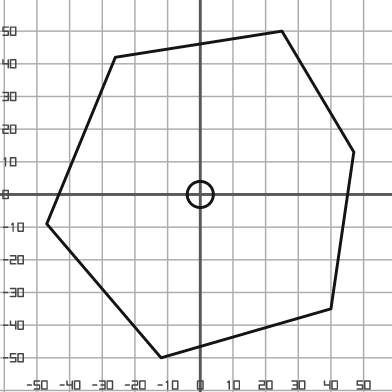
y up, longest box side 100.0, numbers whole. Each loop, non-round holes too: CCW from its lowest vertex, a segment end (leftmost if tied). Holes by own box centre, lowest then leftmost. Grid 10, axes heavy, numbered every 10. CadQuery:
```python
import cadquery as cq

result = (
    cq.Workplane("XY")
    .moveTo(-12.0, -50.0)
    .lineTo(40.0, -35.0)
    .lineTo(47.0, 13.0)
    .lineTo(25.0, 50.0)
    .lineTo(-26.0, 42.0)
    .lineTo(-47.0, -9.0)
    .close()
    .moveTo(0.0, 0.0)
    .circle(4.0)
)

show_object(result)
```